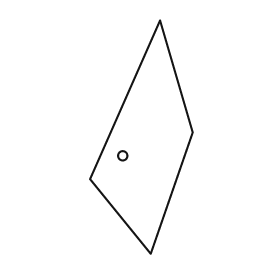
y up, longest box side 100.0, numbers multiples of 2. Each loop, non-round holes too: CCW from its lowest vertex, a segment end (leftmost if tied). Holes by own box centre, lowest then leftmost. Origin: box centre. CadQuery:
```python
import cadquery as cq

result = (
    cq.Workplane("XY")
    .moveTo(4.0, -50.0)
    .lineTo(22.0, 2.0)
    .lineTo(8.0, 50.0)
    .lineTo(-22.0, -18.0)
    .close()
    .moveTo(-8.0, -8.0)
    .circle(2.0)
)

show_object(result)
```